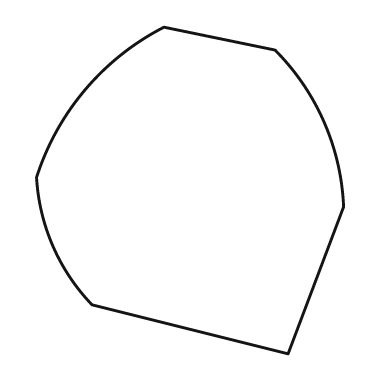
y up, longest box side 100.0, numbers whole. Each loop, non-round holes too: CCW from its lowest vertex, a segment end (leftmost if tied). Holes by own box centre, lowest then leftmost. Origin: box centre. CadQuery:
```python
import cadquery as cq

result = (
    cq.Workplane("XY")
    .moveTo(30.0, -50.0)
    .lineTo(47.0, -5.0)
    .threePointArc((41.0, 21.0), (26.0, 43.0))
    .lineTo(-8.0, 50.0)
    .threePointArc((-32.0, 31.0), (-47.0, 4.0))
    .threePointArc((-42.0, -17.0), (-30.0, -35.0))
    .close()
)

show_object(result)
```